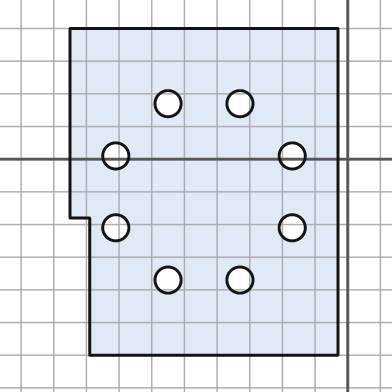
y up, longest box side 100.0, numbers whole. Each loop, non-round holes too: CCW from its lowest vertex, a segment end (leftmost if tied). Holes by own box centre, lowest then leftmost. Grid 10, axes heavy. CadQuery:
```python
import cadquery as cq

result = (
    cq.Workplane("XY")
    .moveTo(-79.0, -60.0)
    .lineTo(-3.0, -60.0)
    .lineTo(-3.0, 40.0)
    .lineTo(-85.0, 40.0)
    .lineTo(-85.0, -18.0)
    .lineTo(-79.0, -18.0)
    .close()
    .moveTo(-55.0, -37.0)
    .circle(4.0)
    .moveTo(-33.0, -37.0)
    .circle(4.0)
    .moveTo(-71.0, -21.0)
    .circle(4.0)
    .moveTo(-17.0, -21.0)
    .circle(4.0)
    .moveTo(-71.0, 1.0)
    .circle(4.0)
    .moveTo(-17.0, 1.0)
    .circle(4.0)
    .moveTo(-55.0, 17.0)
    .circle(4.0)
    .moveTo(-33.0, 17.0)
    .circle(4.0)
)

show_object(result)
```